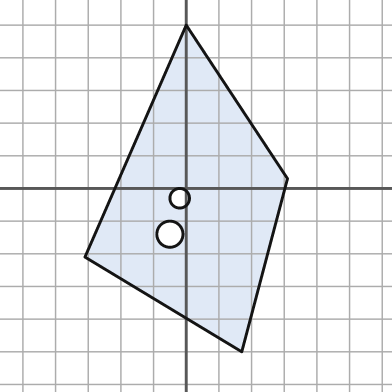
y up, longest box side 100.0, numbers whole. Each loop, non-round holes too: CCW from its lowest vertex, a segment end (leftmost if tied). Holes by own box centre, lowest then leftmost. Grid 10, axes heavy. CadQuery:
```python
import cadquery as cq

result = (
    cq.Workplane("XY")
    .moveTo(17.0, -50.0)
    .lineTo(31.0, 3.0)
    .lineTo(0.0, 50.0)
    .lineTo(-31.0, -21.0)
    .close()
    .moveTo(-5.0, -14.0)
    .circle(4.0)
    .moveTo(-2.0, -3.0)
    .circle(3.0)
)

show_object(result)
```